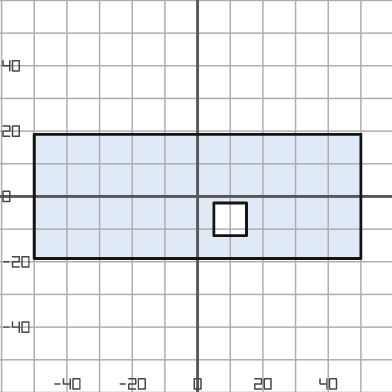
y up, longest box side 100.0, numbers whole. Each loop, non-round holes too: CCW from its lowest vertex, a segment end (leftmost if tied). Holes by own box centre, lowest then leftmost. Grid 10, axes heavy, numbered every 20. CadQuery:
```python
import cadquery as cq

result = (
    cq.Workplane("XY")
    .moveTo(-50.0, -19.0)
    .lineTo(50.0, -19.0)
    .lineTo(50.0, 19.0)
    .lineTo(-50.0, 19.0)
    .close()
    .moveTo(5.0, -12.0)
    .lineTo(15.0, -12.0)
    .lineTo(15.0, -2.0)
    .lineTo(5.0, -2.0)
    .close()
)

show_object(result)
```